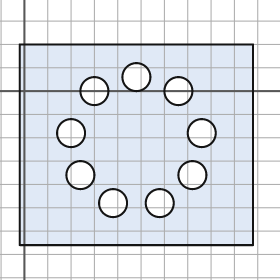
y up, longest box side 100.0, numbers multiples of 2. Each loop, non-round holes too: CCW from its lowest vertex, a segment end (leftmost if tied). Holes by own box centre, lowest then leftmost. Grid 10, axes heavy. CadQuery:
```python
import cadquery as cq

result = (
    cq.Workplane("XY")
    .moveTo(-2.0, -66.0)
    .lineTo(98.0, -66.0)
    .lineTo(98.0, 20.0)
    .lineTo(-2.0, 20.0)
    .close()
    .moveTo(38.0, -48.0)
    .circle(6.0)
    .moveTo(58.0, -48.0)
    .circle(6.0)
    .moveTo(24.0, -36.0)
    .circle(6.0)
    .moveTo(72.0, -36.0)
    .circle(6.0)
    .moveTo(20.0, -18.0)
    .circle(6.0)
    .moveTo(76.0, -18.0)
    .circle(6.0)
    .moveTo(30.0, 0.0)
    .circle(6.0)
    .moveTo(66.0, 0.0)
    .circle(6.0)
    .moveTo(48.0, 6.0)
    .circle(6.0)
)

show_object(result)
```